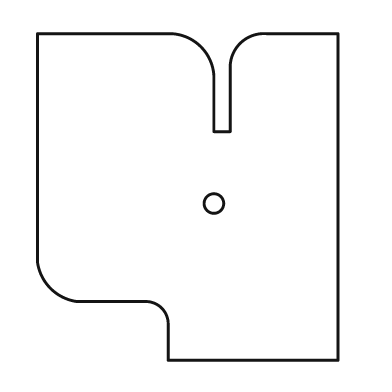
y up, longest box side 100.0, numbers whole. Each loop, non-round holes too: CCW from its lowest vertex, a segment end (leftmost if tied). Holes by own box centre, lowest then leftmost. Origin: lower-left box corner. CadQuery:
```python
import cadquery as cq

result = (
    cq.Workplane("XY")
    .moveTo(40.0, 0.0)
    .lineTo(92.0, 0.0)
    .lineTo(92.0, 100.0)
    .lineTo(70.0, 100.0)
    .threePointArc((62.0, 97.0), (59.0, 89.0))
    .lineTo(59.0, 70.0)
    .lineTo(54.0, 70.0)
    .lineTo(54.0, 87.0)
    .threePointArc((50.0, 96.0), (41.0, 100.0))
    .lineTo(0.0, 100.0)
    .lineTo(0.0, 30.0)
    .threePointArc((4.0, 22.0), (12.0, 18.0))
    .lineTo(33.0, 18.0)
    .threePointArc((38.0, 16.0), (40.0, 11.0))
    .close()
    .moveTo(54.0, 48.0)
    .circle(3.0)
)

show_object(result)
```